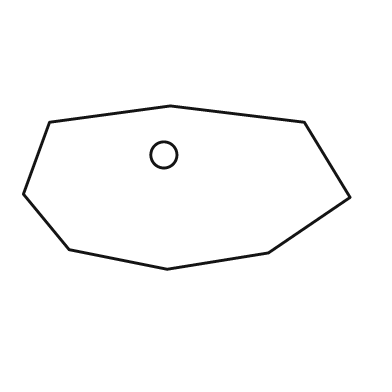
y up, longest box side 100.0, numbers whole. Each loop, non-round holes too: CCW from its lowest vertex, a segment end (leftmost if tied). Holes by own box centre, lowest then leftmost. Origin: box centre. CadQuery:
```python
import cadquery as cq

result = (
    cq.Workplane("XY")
    .moveTo(-6.0, -25.0)
    .lineTo(25.0, -20.0)
    .lineTo(50.0, -3.0)
    .lineTo(36.0, 20.0)
    .lineTo(-5.0, 25.0)
    .lineTo(-42.0, 20.0)
    .lineTo(-50.0, -2.0)
    .lineTo(-36.0, -19.0)
    .close()
    .moveTo(-7.0, 10.0)
    .circle(4.0)
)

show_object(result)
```